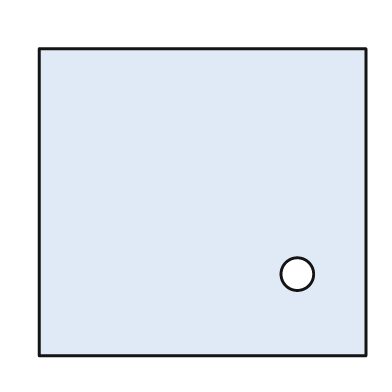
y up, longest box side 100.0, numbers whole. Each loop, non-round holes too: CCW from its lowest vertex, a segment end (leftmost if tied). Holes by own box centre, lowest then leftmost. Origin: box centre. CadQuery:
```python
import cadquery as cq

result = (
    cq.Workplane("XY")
    .moveTo(-50.0, -47.0)
    .lineTo(50.0, -47.0)
    .lineTo(50.0, 47.0)
    .lineTo(-50.0, 47.0)
    .close()
    .moveTo(29.0, -22.0)
    .circle(5.0)
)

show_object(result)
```